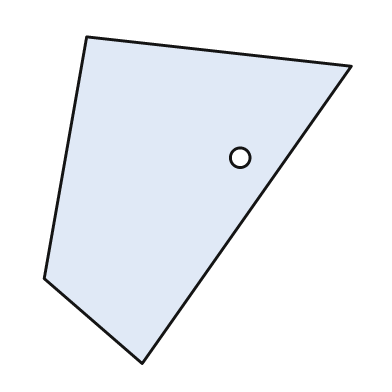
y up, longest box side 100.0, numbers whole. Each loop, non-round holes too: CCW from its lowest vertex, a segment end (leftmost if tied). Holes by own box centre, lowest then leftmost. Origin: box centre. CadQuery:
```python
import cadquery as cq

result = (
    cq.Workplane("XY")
    .moveTo(-17.0, -50.0)
    .lineTo(47.0, 41.0)
    .lineTo(-34.0, 50.0)
    .lineTo(-47.0, -24.0)
    .close()
    .moveTo(13.0, 13.0)
    .circle(3.0)
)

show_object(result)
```